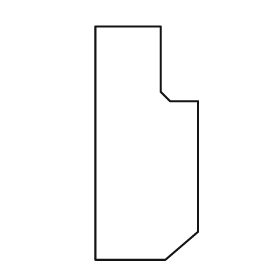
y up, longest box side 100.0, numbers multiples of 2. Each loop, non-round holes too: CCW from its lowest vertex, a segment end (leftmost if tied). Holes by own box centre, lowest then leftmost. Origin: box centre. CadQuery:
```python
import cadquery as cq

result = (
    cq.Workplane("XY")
    .moveTo(-22.0, -50.0)
    .lineTo(8.0, -50.0)
    .lineTo(22.0, -38.0)
    .lineTo(22.0, 18.0)
    .lineTo(10.0, 18.0)
    .lineTo(6.0, 22.0)
    .lineTo(6.0, 50.0)
    .lineTo(-22.0, 50.0)
    .close()
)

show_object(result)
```